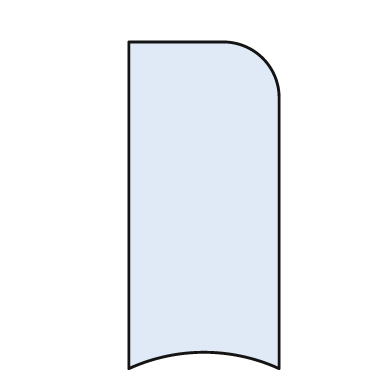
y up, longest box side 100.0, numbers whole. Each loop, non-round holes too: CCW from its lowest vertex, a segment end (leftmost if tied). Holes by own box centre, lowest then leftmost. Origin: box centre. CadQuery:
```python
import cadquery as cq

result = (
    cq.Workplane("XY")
    .moveTo(-23.0, -50.0)
    .threePointArc((0.0, -45.0), (23.0, -50.0))
    .lineTo(23.0, 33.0)
    .threePointArc((18.0, 45.0), (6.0, 50.0))
    .lineTo(-23.0, 50.0)
    .close()
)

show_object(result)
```